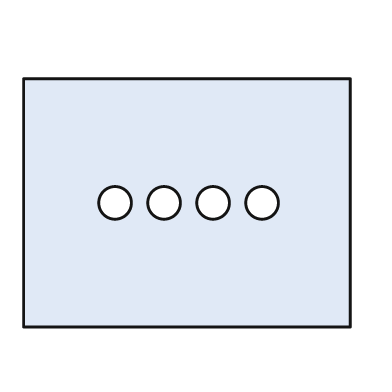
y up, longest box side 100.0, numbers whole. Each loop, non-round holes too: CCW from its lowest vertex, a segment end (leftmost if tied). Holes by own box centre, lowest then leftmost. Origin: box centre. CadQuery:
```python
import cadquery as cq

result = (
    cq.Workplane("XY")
    .moveTo(-50.0, -38.0)
    .lineTo(50.0, -38.0)
    .lineTo(50.0, 38.0)
    .lineTo(-50.0, 38.0)
    .close()
    .moveTo(-22.0, 0.0)
    .circle(5.0)
    .moveTo(-7.0, 0.0)
    .circle(5.0)
    .moveTo(8.0, 0.0)
    .circle(5.0)
    .moveTo(23.0, 0.0)
    .circle(5.0)
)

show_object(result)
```